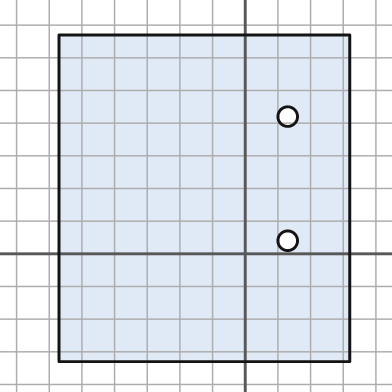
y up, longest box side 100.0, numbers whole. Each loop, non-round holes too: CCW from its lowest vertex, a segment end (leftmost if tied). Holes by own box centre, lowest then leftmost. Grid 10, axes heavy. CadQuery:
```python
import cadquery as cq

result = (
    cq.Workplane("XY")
    .moveTo(-57.0, -33.0)
    .lineTo(32.0, -33.0)
    .lineTo(32.0, 67.0)
    .lineTo(-57.0, 67.0)
    .close()
    .moveTo(13.0, 4.0)
    .circle(3.0)
    .moveTo(13.0, 42.0)
    .circle(3.0)
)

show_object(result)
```